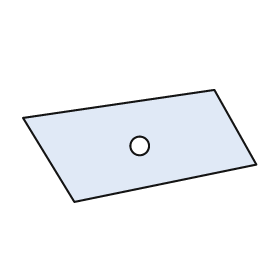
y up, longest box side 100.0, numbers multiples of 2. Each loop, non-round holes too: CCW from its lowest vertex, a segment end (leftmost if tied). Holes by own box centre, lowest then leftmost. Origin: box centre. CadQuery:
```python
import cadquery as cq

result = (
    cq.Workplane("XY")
    .moveTo(-28.0, -24.0)
    .lineTo(50.0, -8.0)
    .lineTo(32.0, 24.0)
    .lineTo(-50.0, 12.0)
    .close()
    .moveTo(0.0, 0.0)
    .circle(4.0)
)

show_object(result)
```